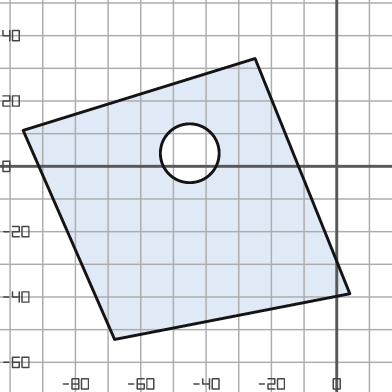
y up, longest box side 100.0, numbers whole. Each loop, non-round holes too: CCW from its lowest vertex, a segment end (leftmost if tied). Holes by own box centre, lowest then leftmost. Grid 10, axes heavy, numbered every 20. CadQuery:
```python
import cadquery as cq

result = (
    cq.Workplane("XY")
    .moveTo(-68.0, -53.0)
    .lineTo(4.0, -39.0)
    .lineTo(-25.0, 33.0)
    .lineTo(-96.0, 11.0)
    .close()
    .moveTo(-45.0, 4.0)
    .circle(9.0)
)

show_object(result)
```